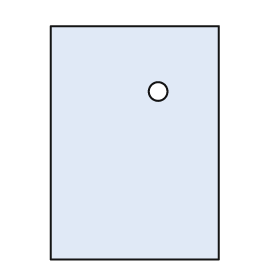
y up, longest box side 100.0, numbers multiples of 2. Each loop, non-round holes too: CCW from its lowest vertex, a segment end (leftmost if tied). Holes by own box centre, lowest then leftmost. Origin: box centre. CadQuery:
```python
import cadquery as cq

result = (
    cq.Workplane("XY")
    .moveTo(-36.0, -50.0)
    .lineTo(36.0, -50.0)
    .lineTo(36.0, 50.0)
    .lineTo(-36.0, 50.0)
    .close()
    .moveTo(10.0, 22.0)
    .circle(4.0)
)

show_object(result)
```